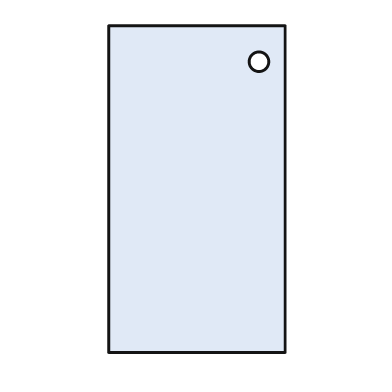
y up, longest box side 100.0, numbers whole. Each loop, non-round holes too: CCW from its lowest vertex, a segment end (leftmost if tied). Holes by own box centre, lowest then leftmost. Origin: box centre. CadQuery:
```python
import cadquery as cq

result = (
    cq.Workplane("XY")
    .moveTo(-27.0, -50.0)
    .lineTo(27.0, -50.0)
    .lineTo(27.0, 50.0)
    .lineTo(-27.0, 50.0)
    .close()
    .moveTo(19.0, 39.0)
    .circle(3.0)
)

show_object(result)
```